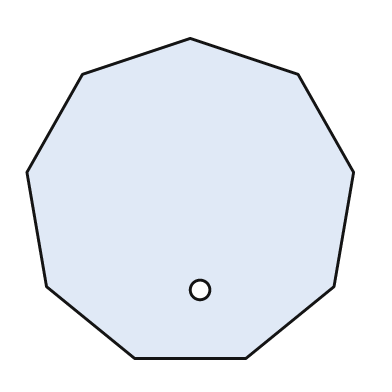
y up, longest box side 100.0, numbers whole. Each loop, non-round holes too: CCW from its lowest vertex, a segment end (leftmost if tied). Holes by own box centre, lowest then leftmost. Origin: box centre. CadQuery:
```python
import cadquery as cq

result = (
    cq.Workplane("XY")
    .moveTo(-17.0, -49.0)
    .lineTo(17.0, -49.0)
    .lineTo(44.0, -27.0)
    .lineTo(50.0, 8.0)
    .lineTo(33.0, 38.0)
    .lineTo(0.0, 49.0)
    .lineTo(-33.0, 38.0)
    .lineTo(-50.0, 8.0)
    .lineTo(-44.0, -27.0)
    .close()
    .moveTo(3.0, -28.0)
    .circle(3.0)
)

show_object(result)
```